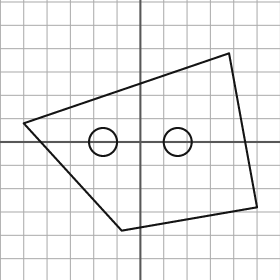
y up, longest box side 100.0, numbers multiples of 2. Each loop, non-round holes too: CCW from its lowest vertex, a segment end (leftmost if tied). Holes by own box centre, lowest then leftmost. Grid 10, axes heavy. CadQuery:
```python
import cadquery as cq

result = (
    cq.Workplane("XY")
    .moveTo(-8.0, -38.0)
    .lineTo(50.0, -28.0)
    .lineTo(38.0, 38.0)
    .lineTo(-50.0, 8.0)
    .close()
    .moveTo(-16.0, 0.0)
    .circle(6.0)
    .moveTo(16.0, 0.0)
    .circle(6.0)
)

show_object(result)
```